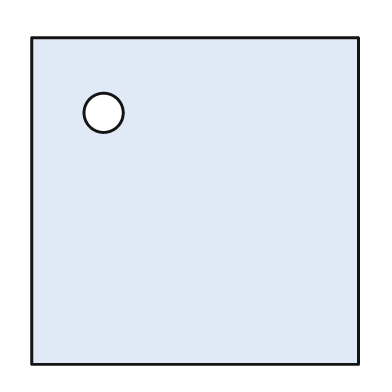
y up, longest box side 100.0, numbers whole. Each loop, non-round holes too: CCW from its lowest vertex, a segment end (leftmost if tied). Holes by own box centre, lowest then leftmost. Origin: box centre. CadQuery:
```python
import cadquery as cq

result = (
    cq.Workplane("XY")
    .moveTo(-50.0, -50.0)
    .lineTo(50.0, -50.0)
    .lineTo(50.0, 50.0)
    .lineTo(-50.0, 50.0)
    .close()
    .moveTo(-28.0, 27.0)
    .circle(6.0)
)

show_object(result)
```